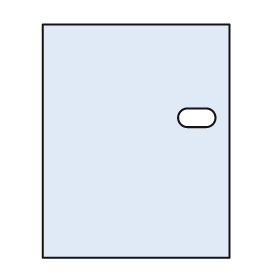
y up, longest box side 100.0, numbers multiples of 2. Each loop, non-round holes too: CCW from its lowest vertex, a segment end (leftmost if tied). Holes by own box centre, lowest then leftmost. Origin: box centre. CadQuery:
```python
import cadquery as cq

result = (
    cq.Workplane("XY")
    .moveTo(-40.0, -50.0)
    .lineTo(40.0, -50.0)
    .lineTo(40.0, 50.0)
    .lineTo(-40.0, 50.0)
    .close()
    .moveTo(22.0, 6.0)
    .lineTo(30.0, 6.0)
    .threePointArc((34.0, 10.0), (30.0, 14.0))
    .lineTo(22.0, 14.0)
    .threePointArc((18.0, 10.0), (22.0, 6.0))
    .close()
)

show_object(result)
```